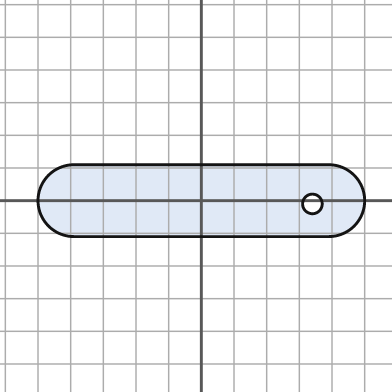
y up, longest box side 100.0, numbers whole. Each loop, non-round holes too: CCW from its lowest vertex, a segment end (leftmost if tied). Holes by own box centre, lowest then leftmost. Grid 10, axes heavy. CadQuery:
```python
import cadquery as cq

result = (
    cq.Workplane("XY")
    .moveTo(-39.0, -11.0)
    .lineTo(39.0, -11.0)
    .threePointArc((50.0, 0.0), (39.0, 11.0))
    .lineTo(-39.0, 11.0)
    .threePointArc((-50.0, 0.0), (-39.0, -11.0))
    .close()
    .moveTo(34.0, -1.0)
    .circle(3.0)
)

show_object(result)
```